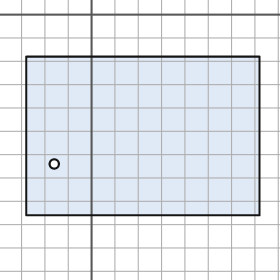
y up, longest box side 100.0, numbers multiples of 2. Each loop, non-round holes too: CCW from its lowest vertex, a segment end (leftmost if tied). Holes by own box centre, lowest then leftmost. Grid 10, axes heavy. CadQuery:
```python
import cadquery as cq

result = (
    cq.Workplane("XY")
    .moveTo(-28.0, -86.0)
    .lineTo(72.0, -86.0)
    .lineTo(72.0, -18.0)
    .lineTo(-28.0, -18.0)
    .close()
    .moveTo(-16.0, -64.0)
    .circle(2.0)
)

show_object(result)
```